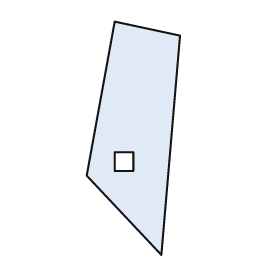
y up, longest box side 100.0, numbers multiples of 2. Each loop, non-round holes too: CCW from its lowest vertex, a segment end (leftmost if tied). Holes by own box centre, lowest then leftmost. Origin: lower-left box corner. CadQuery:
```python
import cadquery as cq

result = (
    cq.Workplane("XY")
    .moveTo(32.0, 0.0)
    .lineTo(40.0, 94.0)
    .lineTo(12.0, 100.0)
    .lineTo(0.0, 34.0)
    .close()
    .moveTo(12.0, 36.0)
    .lineTo(20.0, 36.0)
    .lineTo(20.0, 44.0)
    .lineTo(12.0, 44.0)
    .close()
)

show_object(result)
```